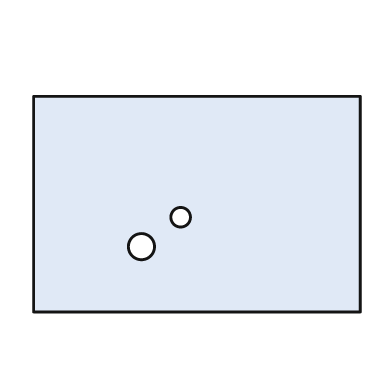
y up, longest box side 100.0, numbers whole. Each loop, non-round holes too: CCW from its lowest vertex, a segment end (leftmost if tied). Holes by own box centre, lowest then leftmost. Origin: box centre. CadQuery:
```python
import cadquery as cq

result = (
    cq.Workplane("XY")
    .moveTo(-50.0, -33.0)
    .lineTo(50.0, -33.0)
    .lineTo(50.0, 33.0)
    .lineTo(-50.0, 33.0)
    .close()
    .moveTo(-17.0, -13.0)
    .circle(4.0)
    .moveTo(-5.0, -4.0)
    .circle(3.0)
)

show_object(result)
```